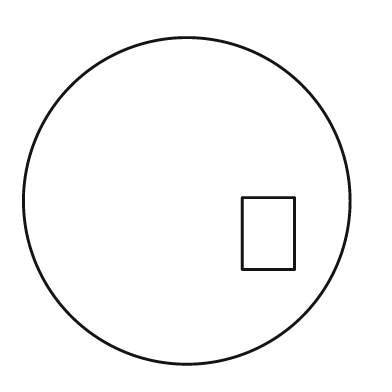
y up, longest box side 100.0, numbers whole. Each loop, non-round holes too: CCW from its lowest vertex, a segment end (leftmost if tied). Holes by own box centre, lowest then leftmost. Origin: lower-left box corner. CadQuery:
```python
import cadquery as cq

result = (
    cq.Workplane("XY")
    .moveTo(50.0, 50.0)
    .circle(50.0)
    .moveTo(67.0, 29.0)
    .lineTo(83.0, 29.0)
    .lineTo(83.0, 51.0)
    .lineTo(67.0, 51.0)
    .close()
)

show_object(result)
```